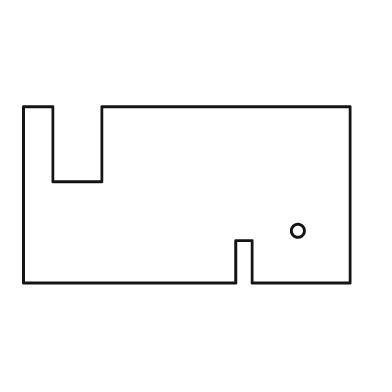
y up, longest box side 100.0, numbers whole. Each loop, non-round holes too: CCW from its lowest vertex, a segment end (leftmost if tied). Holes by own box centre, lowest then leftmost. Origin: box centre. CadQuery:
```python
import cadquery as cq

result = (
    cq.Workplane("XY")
    .moveTo(-50.0, -27.0)
    .lineTo(15.0, -27.0)
    .lineTo(15.0, -14.0)
    .lineTo(20.0, -14.0)
    .lineTo(20.0, -27.0)
    .lineTo(50.0, -27.0)
    .lineTo(50.0, 27.0)
    .lineTo(-26.0, 27.0)
    .lineTo(-26.0, 4.0)
    .lineTo(-41.0, 4.0)
    .lineTo(-41.0, 27.0)
    .lineTo(-50.0, 27.0)
    .close()
    .moveTo(34.0, -11.0)
    .circle(2.0)
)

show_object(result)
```